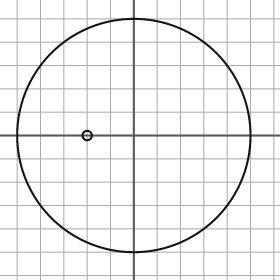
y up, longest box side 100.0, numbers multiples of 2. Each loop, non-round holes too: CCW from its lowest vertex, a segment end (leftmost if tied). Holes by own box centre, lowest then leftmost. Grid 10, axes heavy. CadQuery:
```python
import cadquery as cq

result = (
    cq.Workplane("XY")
    .moveTo(0.0, 0.0)
    .circle(50.0)
    .moveTo(-20.0, 0.0)
    .circle(2.0)
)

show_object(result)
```